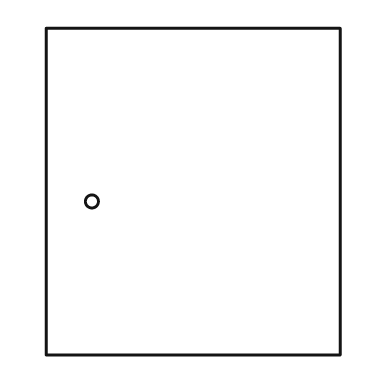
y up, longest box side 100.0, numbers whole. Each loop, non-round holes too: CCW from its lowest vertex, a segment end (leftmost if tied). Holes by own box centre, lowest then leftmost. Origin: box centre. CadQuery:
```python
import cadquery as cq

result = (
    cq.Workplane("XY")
    .moveTo(-45.0, -50.0)
    .lineTo(45.0, -50.0)
    .lineTo(45.0, 50.0)
    .lineTo(-45.0, 50.0)
    .close()
    .moveTo(-31.0, -3.0)
    .circle(2.0)
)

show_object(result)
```